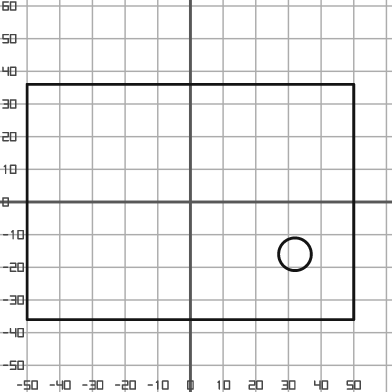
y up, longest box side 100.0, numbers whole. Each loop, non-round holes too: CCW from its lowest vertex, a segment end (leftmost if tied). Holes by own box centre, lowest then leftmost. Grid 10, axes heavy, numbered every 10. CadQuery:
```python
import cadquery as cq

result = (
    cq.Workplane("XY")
    .moveTo(-50.0, -36.0)
    .lineTo(50.0, -36.0)
    .lineTo(50.0, 36.0)
    .lineTo(-50.0, 36.0)
    .close()
    .moveTo(32.0, -16.0)
    .circle(5.0)
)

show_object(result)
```